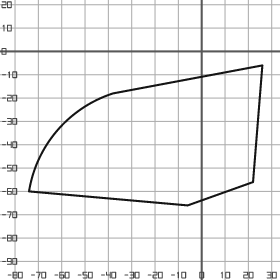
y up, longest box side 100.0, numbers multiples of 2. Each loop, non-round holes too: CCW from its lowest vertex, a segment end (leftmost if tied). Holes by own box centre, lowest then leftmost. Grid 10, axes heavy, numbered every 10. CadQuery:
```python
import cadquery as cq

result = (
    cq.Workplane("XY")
    .moveTo(-6.0, -66.0)
    .lineTo(22.0, -56.0)
    .lineTo(26.0, -6.0)
    .lineTo(-38.0, -18.0)
    .threePointArc((-62.0, -34.0), (-74.0, -60.0))
    .close()
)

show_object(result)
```